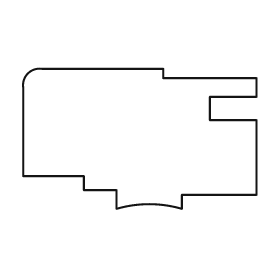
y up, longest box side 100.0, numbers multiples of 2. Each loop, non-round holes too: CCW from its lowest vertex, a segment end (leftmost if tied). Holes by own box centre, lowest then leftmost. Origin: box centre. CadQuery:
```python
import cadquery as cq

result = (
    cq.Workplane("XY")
    .moveTo(-10.0, -30.0)
    .threePointArc((4.0, -28.0), (18.0, -30.0))
    .lineTo(18.0, -24.0)
    .lineTo(50.0, -24.0)
    .lineTo(50.0, 8.0)
    .lineTo(30.0, 8.0)
    .lineTo(30.0, 18.0)
    .lineTo(50.0, 18.0)
    .lineTo(50.0, 26.0)
    .lineTo(10.0, 26.0)
    .lineTo(10.0, 30.0)
    .lineTo(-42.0, 30.0)
    .threePointArc((-48.0, 28.0), (-50.0, 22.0))
    .lineTo(-50.0, -16.0)
    .lineTo(-24.0, -16.0)
    .lineTo(-24.0, -22.0)
    .lineTo(-10.0, -22.0)
    .close()
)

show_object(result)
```